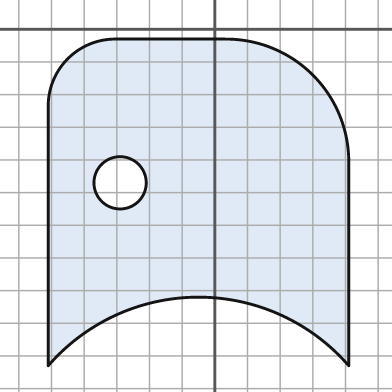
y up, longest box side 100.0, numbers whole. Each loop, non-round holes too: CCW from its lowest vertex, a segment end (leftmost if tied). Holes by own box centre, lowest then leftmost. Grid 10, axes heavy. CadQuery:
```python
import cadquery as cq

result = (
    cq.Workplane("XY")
    .moveTo(-51.0, -103.0)
    .threePointArc((-5.0, -82.0), (41.0, -103.0))
    .lineTo(41.0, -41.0)
    .threePointArc((30.0, -14.0), (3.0, -3.0))
    .lineTo(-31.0, -3.0)
    .threePointArc((-45.0, -9.0), (-51.0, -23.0))
    .close()
    .moveTo(-29.0, -47.0)
    .circle(8.0)
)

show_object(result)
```